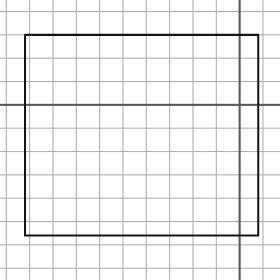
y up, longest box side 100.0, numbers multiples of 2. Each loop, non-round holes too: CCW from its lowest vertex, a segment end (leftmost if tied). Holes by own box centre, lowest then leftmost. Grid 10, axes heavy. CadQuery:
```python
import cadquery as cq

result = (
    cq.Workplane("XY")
    .moveTo(-92.0, -56.0)
    .lineTo(8.0, -56.0)
    .lineTo(8.0, 30.0)
    .lineTo(-92.0, 30.0)
    .close()
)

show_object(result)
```